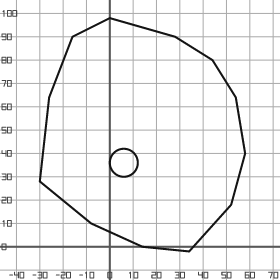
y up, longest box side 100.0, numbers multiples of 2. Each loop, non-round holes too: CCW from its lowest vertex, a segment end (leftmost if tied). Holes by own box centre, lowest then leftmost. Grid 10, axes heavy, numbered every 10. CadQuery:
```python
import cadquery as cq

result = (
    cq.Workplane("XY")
    .moveTo(34.0, -2.0)
    .lineTo(52.0, 18.0)
    .lineTo(58.0, 40.0)
    .lineTo(54.0, 64.0)
    .lineTo(44.0, 80.0)
    .lineTo(28.0, 90.0)
    .lineTo(0.0, 98.0)
    .lineTo(-16.0, 90.0)
    .lineTo(-26.0, 64.0)
    .lineTo(-30.0, 28.0)
    .lineTo(-8.0, 10.0)
    .lineTo(14.0, 0.0)
    .close()
    .moveTo(6.0, 36.0)
    .circle(6.0)
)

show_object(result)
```